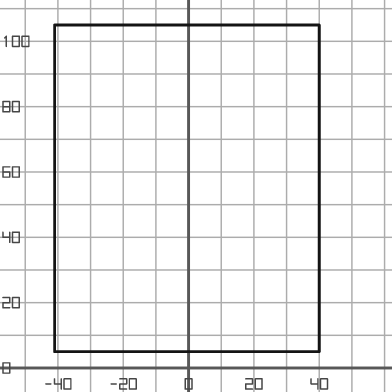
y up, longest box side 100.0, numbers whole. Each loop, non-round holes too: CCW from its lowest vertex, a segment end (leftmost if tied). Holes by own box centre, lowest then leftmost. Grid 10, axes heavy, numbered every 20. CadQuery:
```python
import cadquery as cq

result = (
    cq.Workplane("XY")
    .moveTo(-41.0, 5.0)
    .lineTo(40.0, 5.0)
    .lineTo(40.0, 105.0)
    .lineTo(-41.0, 105.0)
    .close()
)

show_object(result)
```